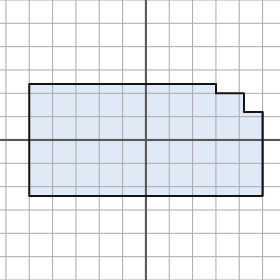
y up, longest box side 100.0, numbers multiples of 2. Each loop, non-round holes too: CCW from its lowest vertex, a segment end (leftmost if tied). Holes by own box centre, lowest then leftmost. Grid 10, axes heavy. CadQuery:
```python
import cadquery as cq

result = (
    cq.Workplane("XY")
    .moveTo(-50.0, -24.0)
    .lineTo(50.0, -24.0)
    .lineTo(50.0, 12.0)
    .lineTo(42.0, 12.0)
    .lineTo(42.0, 20.0)
    .lineTo(30.0, 20.0)
    .lineTo(30.0, 24.0)
    .lineTo(-50.0, 24.0)
    .close()
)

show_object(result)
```